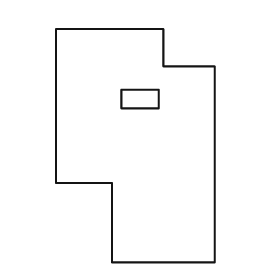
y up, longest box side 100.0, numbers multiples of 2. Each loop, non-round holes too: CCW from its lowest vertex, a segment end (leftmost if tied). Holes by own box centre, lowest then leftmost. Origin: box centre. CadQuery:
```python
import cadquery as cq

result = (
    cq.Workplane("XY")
    .moveTo(-10.0, -50.0)
    .lineTo(34.0, -50.0)
    .lineTo(34.0, 34.0)
    .lineTo(12.0, 34.0)
    .lineTo(12.0, 50.0)
    .lineTo(-34.0, 50.0)
    .lineTo(-34.0, -16.0)
    .lineTo(-10.0, -16.0)
    .close()
    .moveTo(-6.0, 16.0)
    .lineTo(10.0, 16.0)
    .lineTo(10.0, 24.0)
    .lineTo(-6.0, 24.0)
    .close()
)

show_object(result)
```